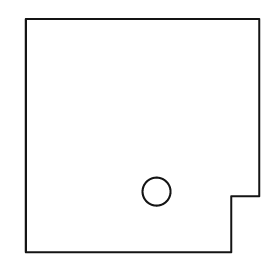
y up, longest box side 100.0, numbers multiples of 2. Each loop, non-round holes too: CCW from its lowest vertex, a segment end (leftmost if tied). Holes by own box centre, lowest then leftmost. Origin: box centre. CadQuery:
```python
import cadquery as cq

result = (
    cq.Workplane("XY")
    .moveTo(-50.0, -50.0)
    .lineTo(38.0, -50.0)
    .lineTo(38.0, -26.0)
    .lineTo(50.0, -26.0)
    .lineTo(50.0, 50.0)
    .lineTo(-50.0, 50.0)
    .close()
    .moveTo(6.0, -24.0)
    .circle(6.0)
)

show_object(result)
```